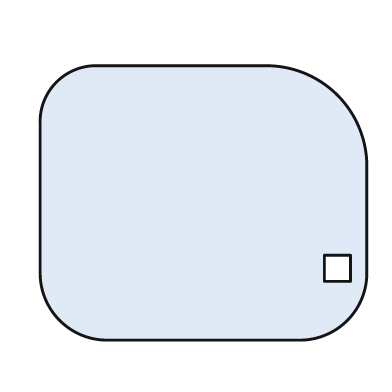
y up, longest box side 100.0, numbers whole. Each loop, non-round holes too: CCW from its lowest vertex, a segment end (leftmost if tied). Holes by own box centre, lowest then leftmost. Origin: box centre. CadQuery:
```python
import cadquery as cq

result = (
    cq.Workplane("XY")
    .moveTo(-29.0, -42.0)
    .lineTo(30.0, -42.0)
    .threePointArc((44.0, -36.0), (50.0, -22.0))
    .lineTo(50.0, 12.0)
    .threePointArc((41.0, 33.0), (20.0, 42.0))
    .lineTo(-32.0, 42.0)
    .threePointArc((-45.0, 37.0), (-50.0, 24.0))
    .lineTo(-50.0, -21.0)
    .threePointArc((-44.0, -36.0), (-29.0, -42.0))
    .close()
    .moveTo(37.0, -24.0)
    .lineTo(45.0, -24.0)
    .lineTo(45.0, -16.0)
    .lineTo(37.0, -16.0)
    .close()
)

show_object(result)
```